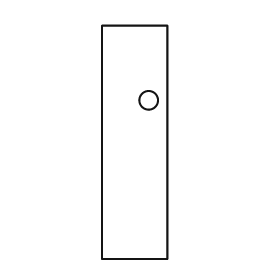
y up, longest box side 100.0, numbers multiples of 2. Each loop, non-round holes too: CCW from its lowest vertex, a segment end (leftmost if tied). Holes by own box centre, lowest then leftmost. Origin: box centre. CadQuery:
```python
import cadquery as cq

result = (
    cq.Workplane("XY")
    .moveTo(-14.0, -50.0)
    .lineTo(14.0, -50.0)
    .lineTo(14.0, 50.0)
    .lineTo(-14.0, 50.0)
    .close()
    .moveTo(6.0, 18.0)
    .circle(4.0)
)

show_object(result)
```